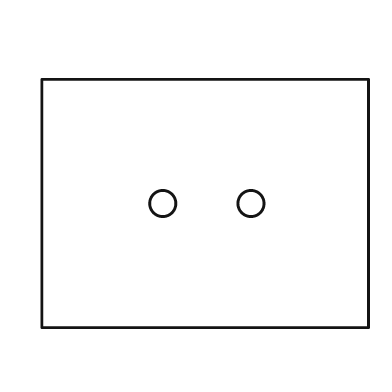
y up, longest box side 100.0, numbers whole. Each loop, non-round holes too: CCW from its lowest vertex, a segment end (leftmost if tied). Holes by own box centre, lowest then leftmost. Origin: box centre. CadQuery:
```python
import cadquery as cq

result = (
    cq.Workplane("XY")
    .moveTo(-50.0, -38.0)
    .lineTo(50.0, -38.0)
    .lineTo(50.0, 38.0)
    .lineTo(-50.0, 38.0)
    .close()
    .moveTo(-13.0, 0.0)
    .circle(4.0)
    .moveTo(14.0, 0.0)
    .circle(4.0)
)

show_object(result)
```